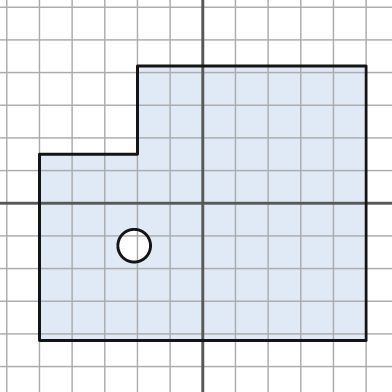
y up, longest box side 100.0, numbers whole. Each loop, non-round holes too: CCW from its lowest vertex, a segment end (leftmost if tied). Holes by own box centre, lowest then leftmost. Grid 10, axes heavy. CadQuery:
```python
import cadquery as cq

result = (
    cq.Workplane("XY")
    .moveTo(-50.0, -42.0)
    .lineTo(50.0, -42.0)
    .lineTo(50.0, 42.0)
    .lineTo(-20.0, 42.0)
    .lineTo(-20.0, 15.0)
    .lineTo(-50.0, 15.0)
    .close()
    .moveTo(-21.0, -13.0)
    .circle(5.0)
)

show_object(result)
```